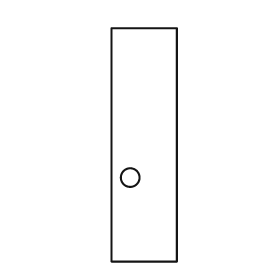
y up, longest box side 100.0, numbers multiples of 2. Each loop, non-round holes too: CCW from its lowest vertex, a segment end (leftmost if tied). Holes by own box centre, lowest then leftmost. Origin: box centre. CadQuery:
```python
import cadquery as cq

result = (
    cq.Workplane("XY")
    .moveTo(-14.0, -50.0)
    .lineTo(14.0, -50.0)
    .lineTo(14.0, 50.0)
    .lineTo(-14.0, 50.0)
    .close()
    .moveTo(-6.0, -14.0)
    .circle(4.0)
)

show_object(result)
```